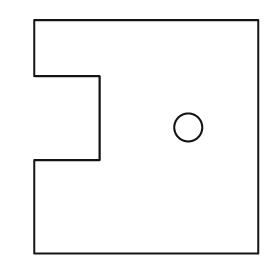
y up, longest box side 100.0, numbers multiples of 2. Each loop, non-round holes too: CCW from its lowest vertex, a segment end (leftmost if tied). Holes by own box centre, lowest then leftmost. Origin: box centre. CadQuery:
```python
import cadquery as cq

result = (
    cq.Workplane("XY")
    .moveTo(-48.0, -50.0)
    .lineTo(48.0, -50.0)
    .lineTo(48.0, 50.0)
    .lineTo(-48.0, 50.0)
    .lineTo(-48.0, 26.0)
    .lineTo(-20.0, 26.0)
    .lineTo(-20.0, -10.0)
    .lineTo(-48.0, -10.0)
    .close()
    .moveTo(18.0, 4.0)
    .circle(6.0)
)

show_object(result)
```